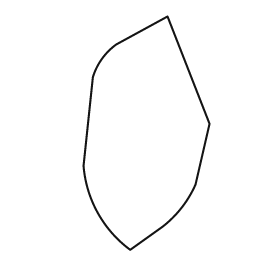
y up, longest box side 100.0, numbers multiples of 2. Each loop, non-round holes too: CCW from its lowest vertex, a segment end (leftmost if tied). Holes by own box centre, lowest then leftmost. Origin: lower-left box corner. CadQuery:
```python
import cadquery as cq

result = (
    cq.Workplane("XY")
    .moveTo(20.0, 0.0)
    .lineTo(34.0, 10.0)
    .threePointArc((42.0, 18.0), (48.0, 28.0))
    .lineTo(54.0, 54.0)
    .lineTo(36.0, 100.0)
    .lineTo(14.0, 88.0)
    .threePointArc((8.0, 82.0), (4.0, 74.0))
    .lineTo(0.0, 36.0)
    .threePointArc((6.0, 16.0), (20.0, 0.0))
    .close()
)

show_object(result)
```